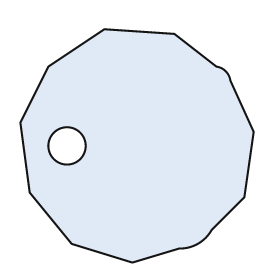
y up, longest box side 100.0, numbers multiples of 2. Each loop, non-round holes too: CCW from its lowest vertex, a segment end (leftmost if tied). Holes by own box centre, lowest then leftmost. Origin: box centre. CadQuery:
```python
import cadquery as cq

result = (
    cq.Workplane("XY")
    .moveTo(-2.0, -50.0)
    .lineTo(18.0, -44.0)
    .threePointArc((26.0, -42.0), (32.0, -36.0))
    .lineTo(46.0, -22.0)
    .lineTo(50.0, 6.0)
    .lineTo(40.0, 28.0)
    .threePointArc((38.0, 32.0), (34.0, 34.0))
    .lineTo(16.0, 48.0)
    .lineTo(-14.0, 50.0)
    .lineTo(-38.0, 34.0)
    .lineTo(-50.0, 10.0)
    .lineTo(-46.0, -20.0)
    .lineTo(-28.0, -42.0)
    .close()
    .moveTo(-30.0, 0.0)
    .circle(8.0)
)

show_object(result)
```